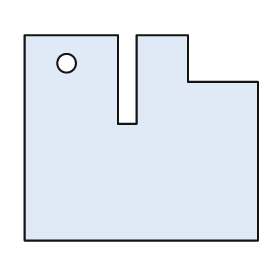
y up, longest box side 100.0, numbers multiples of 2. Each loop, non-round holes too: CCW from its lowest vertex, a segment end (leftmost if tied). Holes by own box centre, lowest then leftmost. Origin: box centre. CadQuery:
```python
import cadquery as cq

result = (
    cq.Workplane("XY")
    .moveTo(-50.0, -44.0)
    .lineTo(50.0, -44.0)
    .lineTo(50.0, 24.0)
    .lineTo(20.0, 24.0)
    .lineTo(20.0, 44.0)
    .lineTo(-2.0, 44.0)
    .lineTo(-2.0, 6.0)
    .lineTo(-10.0, 6.0)
    .lineTo(-10.0, 44.0)
    .lineTo(-50.0, 44.0)
    .close()
    .moveTo(-32.0, 32.0)
    .circle(4.0)
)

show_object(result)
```